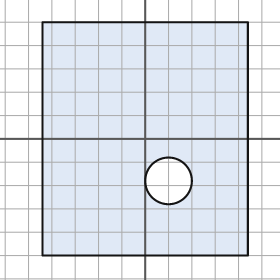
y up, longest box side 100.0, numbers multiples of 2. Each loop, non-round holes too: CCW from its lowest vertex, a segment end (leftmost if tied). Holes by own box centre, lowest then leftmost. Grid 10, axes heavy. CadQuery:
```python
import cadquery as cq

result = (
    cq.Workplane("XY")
    .moveTo(-44.0, -50.0)
    .lineTo(44.0, -50.0)
    .lineTo(44.0, 50.0)
    .lineTo(-44.0, 50.0)
    .close()
    .moveTo(10.0, -18.0)
    .circle(10.0)
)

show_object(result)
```